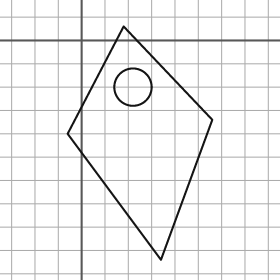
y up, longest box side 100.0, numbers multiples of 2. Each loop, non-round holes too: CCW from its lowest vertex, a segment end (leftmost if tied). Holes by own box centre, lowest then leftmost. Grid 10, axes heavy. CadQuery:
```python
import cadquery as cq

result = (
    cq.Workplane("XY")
    .moveTo(34.0, -94.0)
    .lineTo(56.0, -34.0)
    .lineTo(18.0, 6.0)
    .lineTo(-6.0, -40.0)
    .close()
    .moveTo(22.0, -20.0)
    .circle(8.0)
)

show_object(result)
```